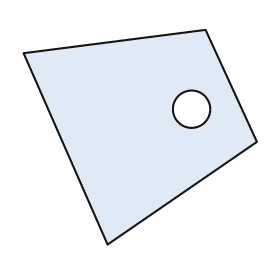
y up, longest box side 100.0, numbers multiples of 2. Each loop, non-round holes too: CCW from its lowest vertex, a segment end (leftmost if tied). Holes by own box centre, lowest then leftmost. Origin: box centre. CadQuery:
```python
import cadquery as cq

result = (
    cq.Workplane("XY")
    .moveTo(-14.0, -46.0)
    .lineTo(50.0, -2.0)
    .lineTo(28.0, 46.0)
    .lineTo(-50.0, 36.0)
    .close()
    .moveTo(22.0, 12.0)
    .circle(8.0)
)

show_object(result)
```